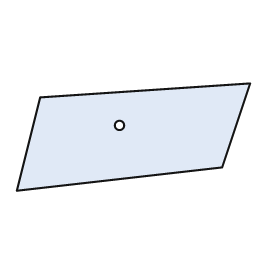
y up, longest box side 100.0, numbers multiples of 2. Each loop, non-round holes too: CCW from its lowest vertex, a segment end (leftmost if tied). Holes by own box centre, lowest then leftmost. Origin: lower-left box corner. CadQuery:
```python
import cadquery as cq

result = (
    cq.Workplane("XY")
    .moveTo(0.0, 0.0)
    .lineTo(88.0, 10.0)
    .lineTo(100.0, 46.0)
    .lineTo(10.0, 40.0)
    .close()
    .moveTo(44.0, 28.0)
    .circle(2.0)
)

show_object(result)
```